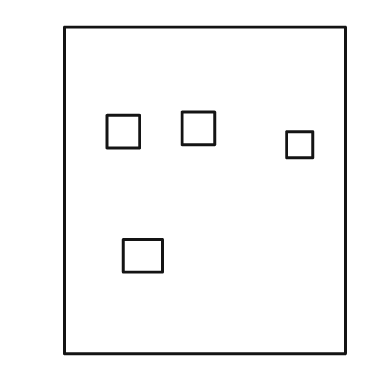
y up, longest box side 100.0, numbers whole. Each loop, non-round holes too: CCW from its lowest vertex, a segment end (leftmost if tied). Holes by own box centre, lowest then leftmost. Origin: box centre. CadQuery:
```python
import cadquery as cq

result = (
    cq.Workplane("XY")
    .moveTo(-43.0, -50.0)
    .lineTo(43.0, -50.0)
    .lineTo(43.0, 50.0)
    .lineTo(-43.0, 50.0)
    .close()
    .moveTo(-25.0, -25.0)
    .lineTo(-13.0, -25.0)
    .lineTo(-13.0, -15.0)
    .lineTo(-25.0, -15.0)
    .close()
    .moveTo(25.0, 10.0)
    .lineTo(33.0, 10.0)
    .lineTo(33.0, 18.0)
    .lineTo(25.0, 18.0)
    .close()
    .moveTo(-30.0, 13.0)
    .lineTo(-20.0, 13.0)
    .lineTo(-20.0, 23.0)
    .lineTo(-30.0, 23.0)
    .close()
    .moveTo(-7.0, 14.0)
    .lineTo(3.0, 14.0)
    .lineTo(3.0, 24.0)
    .lineTo(-7.0, 24.0)
    .close()
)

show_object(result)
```